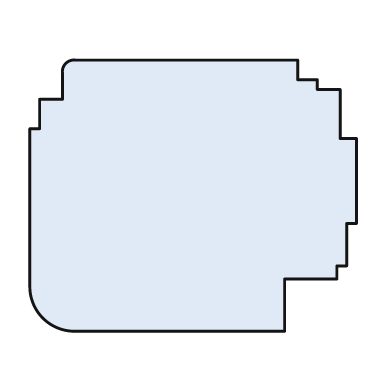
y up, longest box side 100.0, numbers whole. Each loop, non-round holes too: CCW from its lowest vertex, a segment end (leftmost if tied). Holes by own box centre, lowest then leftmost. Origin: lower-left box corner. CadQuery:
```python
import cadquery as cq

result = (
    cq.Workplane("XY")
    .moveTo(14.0, 0.0)
    .lineTo(78.0, 0.0)
    .lineTo(78.0, 16.0)
    .lineTo(94.0, 16.0)
    .lineTo(94.0, 20.0)
    .lineTo(97.0, 20.0)
    .lineTo(97.0, 33.0)
    .lineTo(100.0, 33.0)
    .lineTo(100.0, 59.0)
    .lineTo(95.0, 59.0)
    .lineTo(95.0, 74.0)
    .lineTo(88.0, 74.0)
    .lineTo(88.0, 77.0)
    .lineTo(82.0, 77.0)
    .lineTo(82.0, 83.0)
    .lineTo(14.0, 83.0)
    .threePointArc((11.0, 82.0), (10.0, 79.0))
    .lineTo(10.0, 71.0)
    .lineTo(3.0, 71.0)
    .lineTo(3.0, 62.0)
    .lineTo(0.0, 62.0)
    .lineTo(0.0, 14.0)
    .threePointArc((4.0, 4.0), (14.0, 0.0))
    .close()
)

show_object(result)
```